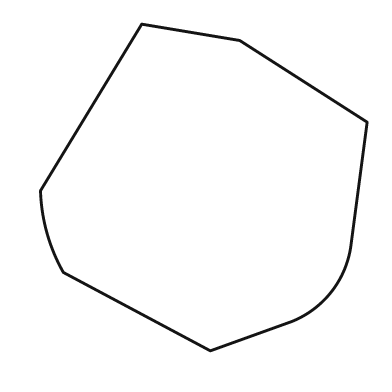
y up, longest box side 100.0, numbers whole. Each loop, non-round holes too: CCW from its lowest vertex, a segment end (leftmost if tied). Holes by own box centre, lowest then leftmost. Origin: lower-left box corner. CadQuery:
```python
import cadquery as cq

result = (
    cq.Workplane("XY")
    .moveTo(52.0, 0.0)
    .lineTo(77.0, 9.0)
    .threePointArc((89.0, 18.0), (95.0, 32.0))
    .lineTo(100.0, 70.0)
    .lineTo(61.0, 95.0)
    .lineTo(31.0, 100.0)
    .lineTo(0.0, 49.0)
    .threePointArc((2.0, 36.0), (7.0, 24.0))
    .close()
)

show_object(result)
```